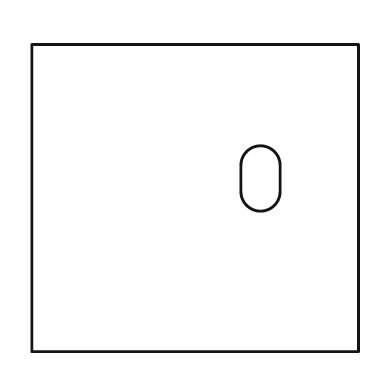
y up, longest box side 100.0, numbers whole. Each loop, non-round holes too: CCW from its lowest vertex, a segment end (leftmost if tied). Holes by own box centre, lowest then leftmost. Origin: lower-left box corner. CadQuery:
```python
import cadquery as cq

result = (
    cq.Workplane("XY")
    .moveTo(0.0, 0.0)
    .lineTo(100.0, 0.0)
    .lineTo(100.0, 94.0)
    .lineTo(0.0, 94.0)
    .close()
    .moveTo(64.0, 49.0)
    .threePointArc((70.0, 43.0), (76.0, 49.0))
    .lineTo(76.0, 57.0)
    .threePointArc((70.0, 63.0), (64.0, 57.0))
    .close()
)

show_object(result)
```